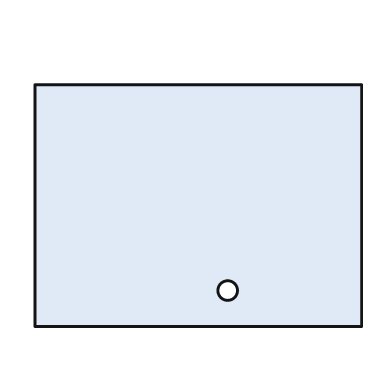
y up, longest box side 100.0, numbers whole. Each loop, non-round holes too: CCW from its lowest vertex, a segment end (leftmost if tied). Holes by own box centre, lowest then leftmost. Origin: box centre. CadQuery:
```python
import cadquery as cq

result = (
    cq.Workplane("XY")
    .moveTo(-50.0, -37.0)
    .lineTo(50.0, -37.0)
    .lineTo(50.0, 37.0)
    .lineTo(-50.0, 37.0)
    .close()
    .moveTo(9.0, -26.0)
    .circle(3.0)
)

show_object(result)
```